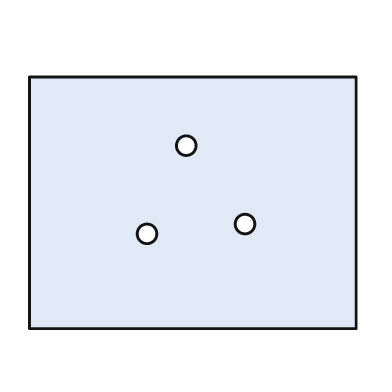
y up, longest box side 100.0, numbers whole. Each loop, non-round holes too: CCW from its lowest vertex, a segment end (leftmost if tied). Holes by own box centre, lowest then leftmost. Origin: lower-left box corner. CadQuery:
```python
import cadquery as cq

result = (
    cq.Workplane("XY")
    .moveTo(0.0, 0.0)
    .lineTo(100.0, 0.0)
    .lineTo(100.0, 77.0)
    .lineTo(0.0, 77.0)
    .close()
    .moveTo(36.0, 29.0)
    .circle(3.0)
    .moveTo(66.0, 32.0)
    .circle(3.0)
    .moveTo(48.0, 56.0)
    .circle(3.0)
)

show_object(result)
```